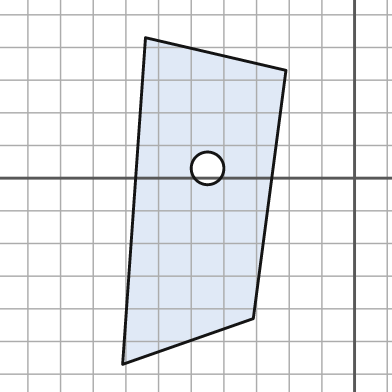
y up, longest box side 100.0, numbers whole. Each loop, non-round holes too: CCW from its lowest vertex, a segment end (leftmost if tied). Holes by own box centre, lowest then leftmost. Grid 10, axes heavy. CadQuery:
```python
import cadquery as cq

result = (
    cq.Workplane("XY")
    .moveTo(-71.0, -57.0)
    .lineTo(-31.0, -43.0)
    .lineTo(-21.0, 33.0)
    .lineTo(-64.0, 43.0)
    .close()
    .moveTo(-45.0, 3.0)
    .circle(5.0)
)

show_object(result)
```